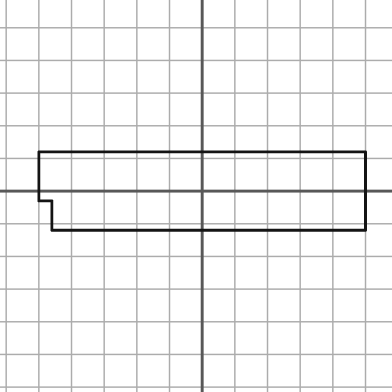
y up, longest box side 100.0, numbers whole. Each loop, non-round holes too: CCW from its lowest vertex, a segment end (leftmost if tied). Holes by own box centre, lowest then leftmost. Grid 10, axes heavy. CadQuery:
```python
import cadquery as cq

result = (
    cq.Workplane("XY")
    .moveTo(-46.0, -12.0)
    .lineTo(50.0, -12.0)
    .lineTo(50.0, 12.0)
    .lineTo(-50.0, 12.0)
    .lineTo(-50.0, -3.0)
    .lineTo(-46.0, -3.0)
    .close()
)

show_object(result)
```